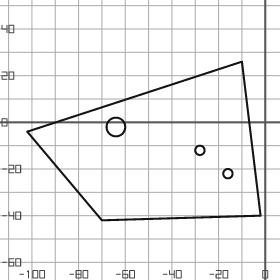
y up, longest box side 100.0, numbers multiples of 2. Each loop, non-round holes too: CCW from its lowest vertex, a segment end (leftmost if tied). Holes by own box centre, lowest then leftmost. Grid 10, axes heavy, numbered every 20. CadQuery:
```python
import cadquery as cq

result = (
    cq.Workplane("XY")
    .moveTo(-70.0, -42.0)
    .lineTo(-2.0, -40.0)
    .lineTo(-10.0, 26.0)
    .lineTo(-102.0, -4.0)
    .close()
    .moveTo(-16.0, -22.0)
    .circle(2.0)
    .moveTo(-28.0, -12.0)
    .circle(2.0)
    .moveTo(-64.0, -2.0)
    .circle(4.0)
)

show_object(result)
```